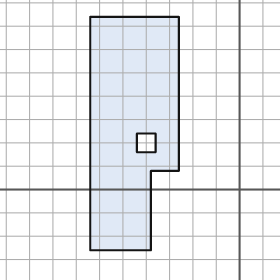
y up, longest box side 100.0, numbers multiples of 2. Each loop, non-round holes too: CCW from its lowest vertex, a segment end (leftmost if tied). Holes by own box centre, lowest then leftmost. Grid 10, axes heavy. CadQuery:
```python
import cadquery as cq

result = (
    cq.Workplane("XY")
    .moveTo(-64.0, -26.0)
    .lineTo(-38.0, -26.0)
    .lineTo(-38.0, 8.0)
    .lineTo(-26.0, 8.0)
    .lineTo(-26.0, 74.0)
    .lineTo(-64.0, 74.0)
    .close()
    .moveTo(-44.0, 16.0)
    .lineTo(-36.0, 16.0)
    .lineTo(-36.0, 24.0)
    .lineTo(-44.0, 24.0)
    .close()
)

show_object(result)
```